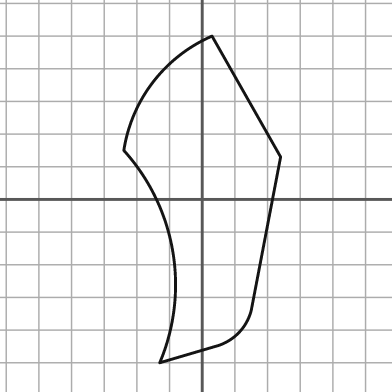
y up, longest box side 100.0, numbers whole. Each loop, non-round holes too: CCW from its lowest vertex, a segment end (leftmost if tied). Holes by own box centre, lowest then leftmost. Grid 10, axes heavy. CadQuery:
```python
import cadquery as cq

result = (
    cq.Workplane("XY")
    .moveTo(-13.0, -50.0)
    .lineTo(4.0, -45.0)
    .threePointArc((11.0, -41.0), (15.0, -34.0))
    .lineTo(24.0, 13.0)
    .lineTo(3.0, 50.0)
    .threePointArc((-15.0, 36.0), (-24.0, 15.0))
    .threePointArc((-9.0, -16.0), (-13.0, -50.0))
    .close()
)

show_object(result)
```